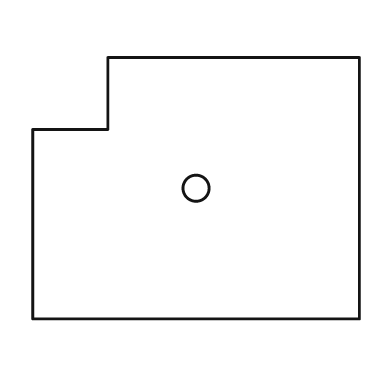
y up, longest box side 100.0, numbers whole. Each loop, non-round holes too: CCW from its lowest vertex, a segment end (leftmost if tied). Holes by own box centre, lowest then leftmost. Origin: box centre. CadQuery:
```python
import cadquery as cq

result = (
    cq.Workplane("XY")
    .moveTo(-50.0, -40.0)
    .lineTo(50.0, -40.0)
    .lineTo(50.0, 40.0)
    .lineTo(-27.0, 40.0)
    .lineTo(-27.0, 18.0)
    .lineTo(-50.0, 18.0)
    .close()
    .moveTo(0.0, 0.0)
    .circle(4.0)
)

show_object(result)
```